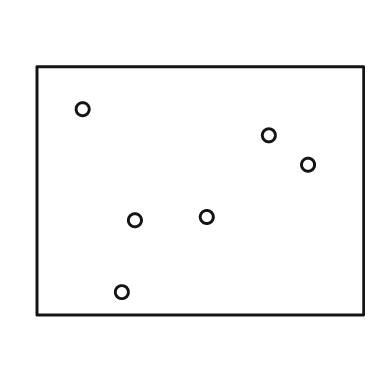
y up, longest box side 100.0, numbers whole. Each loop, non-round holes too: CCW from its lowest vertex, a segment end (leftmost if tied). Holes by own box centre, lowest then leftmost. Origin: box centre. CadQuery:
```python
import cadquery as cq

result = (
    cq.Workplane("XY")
    .moveTo(-50.0, -38.0)
    .lineTo(50.0, -38.0)
    .lineTo(50.0, 38.0)
    .lineTo(-50.0, 38.0)
    .close()
    .moveTo(-24.0, -31.0)
    .circle(2.0)
    .moveTo(-20.0, -9.0)
    .circle(2.0)
    .moveTo(2.0, -8.0)
    .circle(2.0)
    .moveTo(33.0, 8.0)
    .circle(2.0)
    .moveTo(21.0, 17.0)
    .circle(2.0)
    .moveTo(-36.0, 25.0)
    .circle(2.0)
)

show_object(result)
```